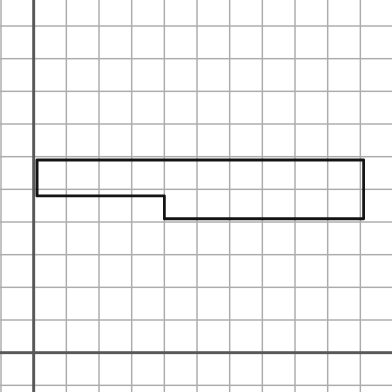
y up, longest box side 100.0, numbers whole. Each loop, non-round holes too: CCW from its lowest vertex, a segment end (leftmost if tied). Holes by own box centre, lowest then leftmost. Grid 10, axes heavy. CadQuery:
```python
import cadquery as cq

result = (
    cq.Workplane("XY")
    .moveTo(40.0, 41.0)
    .lineTo(101.0, 41.0)
    .lineTo(101.0, 59.0)
    .lineTo(1.0, 59.0)
    .lineTo(1.0, 48.0)
    .lineTo(40.0, 48.0)
    .close()
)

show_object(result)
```